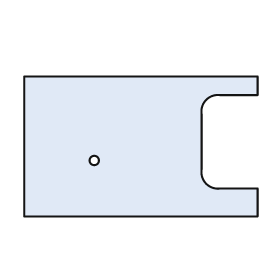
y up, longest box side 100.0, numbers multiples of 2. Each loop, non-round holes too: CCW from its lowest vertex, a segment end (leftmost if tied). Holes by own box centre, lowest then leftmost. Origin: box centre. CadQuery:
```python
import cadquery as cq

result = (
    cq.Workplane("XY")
    .moveTo(-50.0, -30.0)
    .lineTo(50.0, -30.0)
    .lineTo(50.0, -18.0)
    .lineTo(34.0, -18.0)
    .threePointArc((28.0, -16.0), (26.0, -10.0))
    .lineTo(26.0, 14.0)
    .threePointArc((28.0, 20.0), (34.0, 22.0))
    .lineTo(50.0, 22.0)
    .lineTo(50.0, 30.0)
    .lineTo(-50.0, 30.0)
    .close()
    .moveTo(-20.0, -6.0)
    .circle(2.0)
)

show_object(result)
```